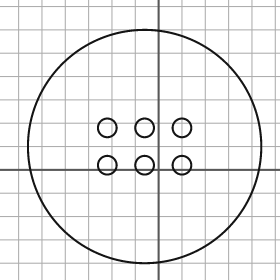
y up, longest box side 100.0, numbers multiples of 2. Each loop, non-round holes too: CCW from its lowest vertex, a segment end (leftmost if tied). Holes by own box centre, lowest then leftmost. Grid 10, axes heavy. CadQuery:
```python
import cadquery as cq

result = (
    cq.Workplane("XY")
    .moveTo(-6.0, 10.0)
    .circle(50.0)
    .moveTo(-22.0, 2.0)
    .circle(4.0)
    .moveTo(-6.0, 2.0)
    .circle(4.0)
    .moveTo(10.0, 2.0)
    .circle(4.0)
    .moveTo(-22.0, 18.0)
    .circle(4.0)
    .moveTo(-6.0, 18.0)
    .circle(4.0)
    .moveTo(10.0, 18.0)
    .circle(4.0)
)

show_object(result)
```